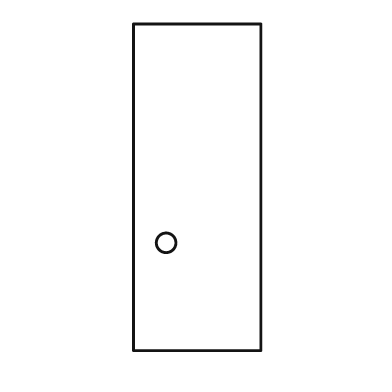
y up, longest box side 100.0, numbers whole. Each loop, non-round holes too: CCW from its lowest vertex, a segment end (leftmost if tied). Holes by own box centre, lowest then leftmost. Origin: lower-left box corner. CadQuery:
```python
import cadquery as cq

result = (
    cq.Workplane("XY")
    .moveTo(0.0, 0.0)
    .lineTo(39.0, 0.0)
    .lineTo(39.0, 100.0)
    .lineTo(0.0, 100.0)
    .close()
    .moveTo(10.0, 33.0)
    .circle(3.0)
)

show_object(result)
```